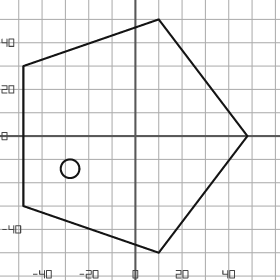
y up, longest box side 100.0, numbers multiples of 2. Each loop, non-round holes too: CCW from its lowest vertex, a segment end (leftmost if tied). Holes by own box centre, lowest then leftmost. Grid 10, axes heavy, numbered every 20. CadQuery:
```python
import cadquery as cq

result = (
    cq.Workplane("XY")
    .moveTo(10.0, -50.0)
    .lineTo(48.0, 0.0)
    .lineTo(10.0, 50.0)
    .lineTo(-48.0, 30.0)
    .lineTo(-48.0, -30.0)
    .close()
    .moveTo(-28.0, -14.0)
    .circle(4.0)
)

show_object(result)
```